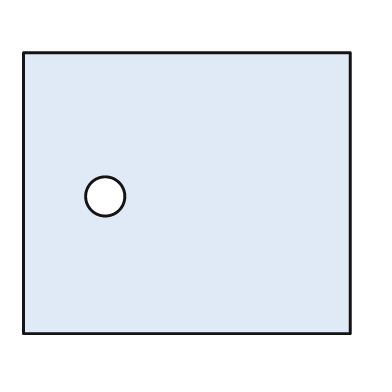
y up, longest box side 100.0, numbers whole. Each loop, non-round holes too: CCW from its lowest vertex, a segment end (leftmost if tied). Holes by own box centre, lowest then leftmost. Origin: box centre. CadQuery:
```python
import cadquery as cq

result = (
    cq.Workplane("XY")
    .moveTo(-50.0, -43.0)
    .lineTo(50.0, -43.0)
    .lineTo(50.0, 43.0)
    .lineTo(-50.0, 43.0)
    .close()
    .moveTo(-25.0, -1.0)
    .circle(6.0)
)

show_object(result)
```